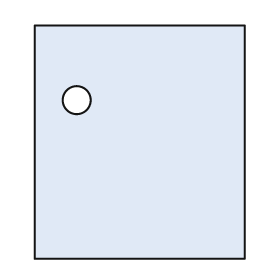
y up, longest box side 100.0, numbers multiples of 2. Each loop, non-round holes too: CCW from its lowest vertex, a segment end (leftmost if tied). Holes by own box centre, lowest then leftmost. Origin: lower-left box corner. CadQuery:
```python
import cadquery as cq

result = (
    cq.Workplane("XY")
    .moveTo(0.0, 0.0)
    .lineTo(90.0, 0.0)
    .lineTo(90.0, 100.0)
    .lineTo(0.0, 100.0)
    .close()
    .moveTo(18.0, 68.0)
    .circle(6.0)
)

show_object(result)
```